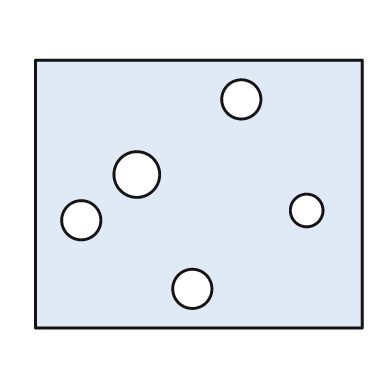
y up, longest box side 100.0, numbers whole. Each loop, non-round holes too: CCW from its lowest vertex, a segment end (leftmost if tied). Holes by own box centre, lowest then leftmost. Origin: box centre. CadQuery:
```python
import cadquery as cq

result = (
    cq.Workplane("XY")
    .moveTo(-50.0, -41.0)
    .lineTo(50.0, -41.0)
    .lineTo(50.0, 41.0)
    .lineTo(-50.0, 41.0)
    .close()
    .moveTo(-2.0, -29.0)
    .circle(6.0)
    .moveTo(-36.0, -8.0)
    .circle(6.0)
    .moveTo(33.0, -5.0)
    .circle(5.0)
    .moveTo(-19.0, 6.0)
    .circle(7.0)
    .moveTo(13.0, 29.0)
    .circle(6.0)
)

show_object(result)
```